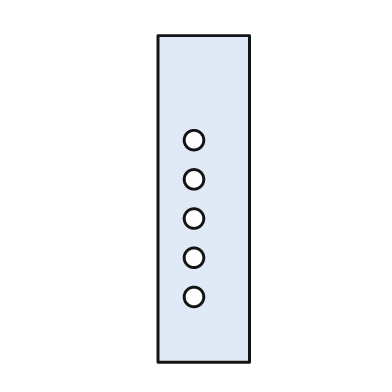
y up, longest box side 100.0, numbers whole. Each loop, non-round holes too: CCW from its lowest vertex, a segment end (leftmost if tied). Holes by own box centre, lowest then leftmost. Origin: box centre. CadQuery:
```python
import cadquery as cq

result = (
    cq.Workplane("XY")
    .moveTo(-14.0, -50.0)
    .lineTo(14.0, -50.0)
    .lineTo(14.0, 50.0)
    .lineTo(-14.0, 50.0)
    .close()
    .moveTo(-3.0, -30.0)
    .circle(3.0)
    .moveTo(-3.0, -18.0)
    .circle(3.0)
    .moveTo(-3.0, -6.0)
    .circle(3.0)
    .moveTo(-3.0, 6.0)
    .circle(3.0)
    .moveTo(-3.0, 18.0)
    .circle(3.0)
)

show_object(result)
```